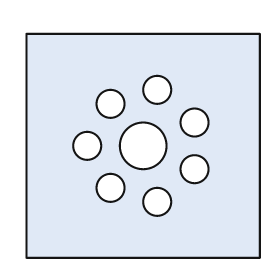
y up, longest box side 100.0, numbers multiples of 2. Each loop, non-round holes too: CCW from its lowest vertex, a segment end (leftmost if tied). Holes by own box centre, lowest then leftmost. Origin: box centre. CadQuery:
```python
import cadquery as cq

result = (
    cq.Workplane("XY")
    .moveTo(-50.0, -48.0)
    .lineTo(50.0, -48.0)
    .lineTo(50.0, 48.0)
    .lineTo(-50.0, 48.0)
    .close()
    .moveTo(6.0, -24.0)
    .circle(6.0)
    .moveTo(-14.0, -18.0)
    .circle(6.0)
    .moveTo(22.0, -10.0)
    .circle(6.0)
    .moveTo(-24.0, 0.0)
    .circle(6.0)
    .moveTo(0.0, 0.0)
    .circle(10.0)
    .moveTo(22.0, 10.0)
    .circle(6.0)
    .moveTo(-14.0, 18.0)
    .circle(6.0)
    .moveTo(6.0, 24.0)
    .circle(6.0)
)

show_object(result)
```